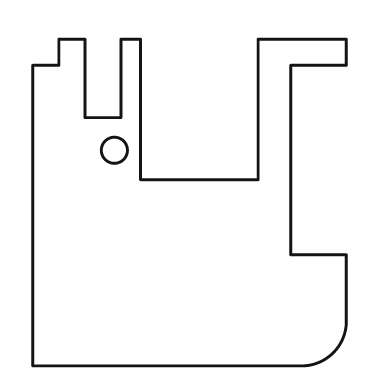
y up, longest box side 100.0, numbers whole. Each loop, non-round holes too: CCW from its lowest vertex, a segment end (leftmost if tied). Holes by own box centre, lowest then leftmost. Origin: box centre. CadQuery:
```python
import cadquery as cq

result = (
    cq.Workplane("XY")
    .moveTo(-48.0, -50.0)
    .lineTo(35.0, -50.0)
    .threePointArc((44.0, -46.0), (48.0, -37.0))
    .lineTo(48.0, -16.0)
    .lineTo(31.0, -16.0)
    .lineTo(31.0, 42.0)
    .lineTo(48.0, 42.0)
    .lineTo(48.0, 50.0)
    .lineTo(21.0, 50.0)
    .lineTo(21.0, 7.0)
    .lineTo(-15.0, 7.0)
    .lineTo(-15.0, 50.0)
    .lineTo(-21.0, 50.0)
    .lineTo(-21.0, 26.0)
    .lineTo(-32.0, 26.0)
    .lineTo(-32.0, 50.0)
    .lineTo(-40.0, 50.0)
    .lineTo(-40.0, 42.0)
    .lineTo(-48.0, 42.0)
    .close()
    .moveTo(-23.0, 16.0)
    .circle(4.0)
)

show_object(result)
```